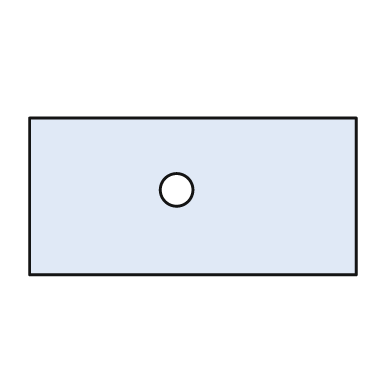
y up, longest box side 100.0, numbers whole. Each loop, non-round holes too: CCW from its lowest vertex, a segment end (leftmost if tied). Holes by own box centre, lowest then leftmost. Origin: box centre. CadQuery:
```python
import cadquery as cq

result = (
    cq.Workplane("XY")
    .moveTo(-50.0, -24.0)
    .lineTo(50.0, -24.0)
    .lineTo(50.0, 24.0)
    .lineTo(-50.0, 24.0)
    .close()
    .moveTo(-5.0, 2.0)
    .circle(5.0)
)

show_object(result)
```